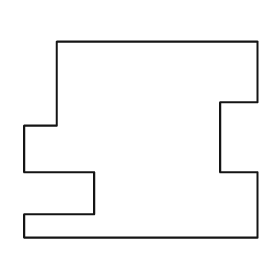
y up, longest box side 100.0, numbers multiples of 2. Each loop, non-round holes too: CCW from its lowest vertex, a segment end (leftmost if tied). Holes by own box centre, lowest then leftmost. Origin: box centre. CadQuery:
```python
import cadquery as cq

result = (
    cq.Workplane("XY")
    .moveTo(-50.0, -42.0)
    .lineTo(50.0, -42.0)
    .lineTo(50.0, -14.0)
    .lineTo(34.0, -14.0)
    .lineTo(34.0, 16.0)
    .lineTo(50.0, 16.0)
    .lineTo(50.0, 42.0)
    .lineTo(-36.0, 42.0)
    .lineTo(-36.0, 6.0)
    .lineTo(-50.0, 6.0)
    .lineTo(-50.0, -14.0)
    .lineTo(-20.0, -14.0)
    .lineTo(-20.0, -32.0)
    .lineTo(-50.0, -32.0)
    .close()
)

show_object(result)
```